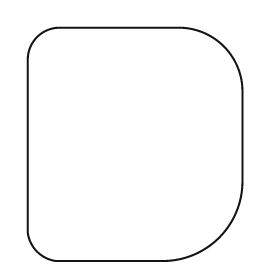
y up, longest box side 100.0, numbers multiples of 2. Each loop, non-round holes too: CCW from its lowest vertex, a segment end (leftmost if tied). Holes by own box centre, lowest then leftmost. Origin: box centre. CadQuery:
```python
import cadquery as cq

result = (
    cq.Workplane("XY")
    .moveTo(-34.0, -50.0)
    .lineTo(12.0, -50.0)
    .threePointArc((36.0, -40.0), (46.0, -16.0))
    .lineTo(46.0, 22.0)
    .threePointArc((38.0, 42.0), (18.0, 50.0))
    .lineTo(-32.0, 50.0)
    .threePointArc((-42.0, 46.0), (-46.0, 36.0))
    .lineTo(-46.0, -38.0)
    .threePointArc((-42.0, -46.0), (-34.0, -50.0))
    .close()
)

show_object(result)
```